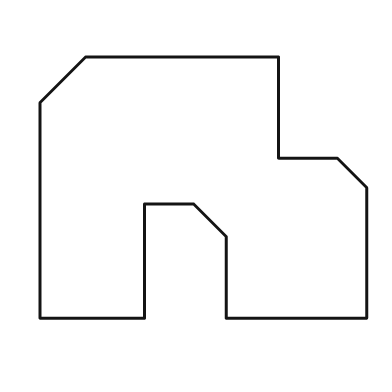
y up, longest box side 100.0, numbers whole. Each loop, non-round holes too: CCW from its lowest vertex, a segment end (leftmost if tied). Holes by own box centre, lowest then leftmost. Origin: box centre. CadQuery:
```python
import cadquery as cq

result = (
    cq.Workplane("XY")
    .moveTo(-50.0, -40.0)
    .lineTo(-18.0, -40.0)
    .lineTo(-18.0, -5.0)
    .lineTo(-3.0, -5.0)
    .lineTo(7.0, -15.0)
    .lineTo(7.0, -40.0)
    .lineTo(50.0, -40.0)
    .lineTo(50.0, 0.0)
    .lineTo(41.0, 9.0)
    .lineTo(23.0, 9.0)
    .lineTo(23.0, 40.0)
    .lineTo(-36.0, 40.0)
    .lineTo(-50.0, 26.0)
    .close()
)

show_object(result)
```